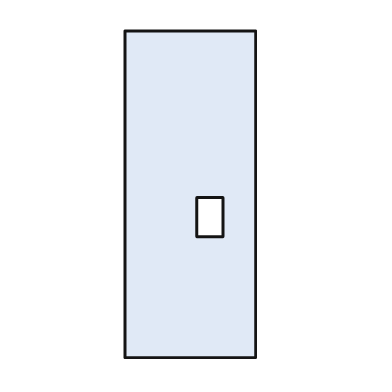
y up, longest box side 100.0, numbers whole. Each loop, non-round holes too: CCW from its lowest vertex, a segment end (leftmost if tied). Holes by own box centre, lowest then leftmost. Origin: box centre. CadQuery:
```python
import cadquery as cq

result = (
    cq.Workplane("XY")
    .moveTo(-20.0, -50.0)
    .lineTo(20.0, -50.0)
    .lineTo(20.0, 50.0)
    .lineTo(-20.0, 50.0)
    .close()
    .moveTo(2.0, -13.0)
    .lineTo(10.0, -13.0)
    .lineTo(10.0, -1.0)
    .lineTo(2.0, -1.0)
    .close()
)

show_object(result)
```